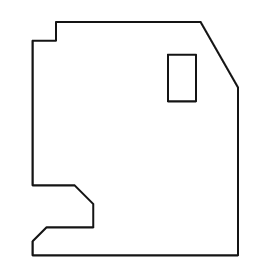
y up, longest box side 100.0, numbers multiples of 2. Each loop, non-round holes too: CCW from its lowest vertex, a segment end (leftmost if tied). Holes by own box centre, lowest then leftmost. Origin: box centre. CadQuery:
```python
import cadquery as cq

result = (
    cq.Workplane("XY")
    .moveTo(-44.0, -50.0)
    .lineTo(44.0, -50.0)
    .lineTo(44.0, 22.0)
    .lineTo(28.0, 50.0)
    .lineTo(-34.0, 50.0)
    .lineTo(-34.0, 42.0)
    .lineTo(-44.0, 42.0)
    .lineTo(-44.0, -20.0)
    .lineTo(-26.0, -20.0)
    .lineTo(-18.0, -28.0)
    .lineTo(-18.0, -38.0)
    .lineTo(-38.0, -38.0)
    .lineTo(-44.0, -44.0)
    .close()
    .moveTo(14.0, 16.0)
    .lineTo(26.0, 16.0)
    .lineTo(26.0, 36.0)
    .lineTo(14.0, 36.0)
    .close()
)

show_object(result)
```